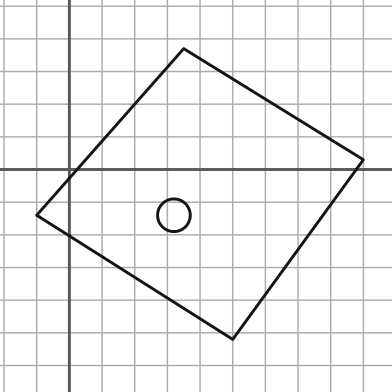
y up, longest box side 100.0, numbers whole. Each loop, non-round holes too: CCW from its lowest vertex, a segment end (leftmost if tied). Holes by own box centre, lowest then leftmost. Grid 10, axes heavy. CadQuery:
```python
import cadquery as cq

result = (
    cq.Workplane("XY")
    .moveTo(50.0, -52.0)
    .lineTo(90.0, 3.0)
    .lineTo(35.0, 37.0)
    .lineTo(-10.0, -14.0)
    .close()
    .moveTo(32.0, -14.0)
    .circle(5.0)
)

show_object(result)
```